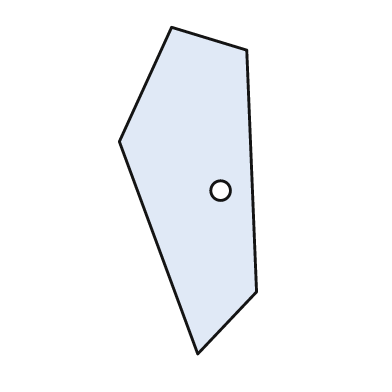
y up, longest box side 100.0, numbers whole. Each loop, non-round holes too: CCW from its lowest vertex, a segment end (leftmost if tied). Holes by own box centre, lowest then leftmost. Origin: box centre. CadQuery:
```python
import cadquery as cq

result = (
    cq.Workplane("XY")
    .moveTo(3.0, -50.0)
    .lineTo(21.0, -31.0)
    .lineTo(18.0, 43.0)
    .lineTo(-5.0, 50.0)
    .lineTo(-21.0, 15.0)
    .close()
    .moveTo(10.0, 0.0)
    .circle(3.0)
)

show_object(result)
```